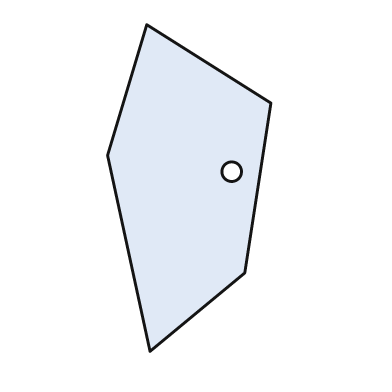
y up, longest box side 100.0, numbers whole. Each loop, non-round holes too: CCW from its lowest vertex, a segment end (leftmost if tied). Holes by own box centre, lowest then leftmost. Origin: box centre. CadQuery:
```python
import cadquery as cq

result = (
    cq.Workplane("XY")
    .moveTo(-12.0, -50.0)
    .lineTo(17.0, -26.0)
    .lineTo(25.0, 26.0)
    .lineTo(-13.0, 50.0)
    .lineTo(-25.0, 10.0)
    .close()
    .moveTo(13.0, 5.0)
    .circle(3.0)
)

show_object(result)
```